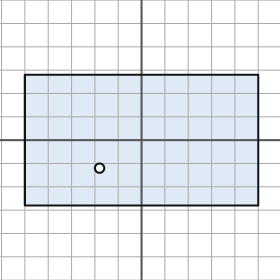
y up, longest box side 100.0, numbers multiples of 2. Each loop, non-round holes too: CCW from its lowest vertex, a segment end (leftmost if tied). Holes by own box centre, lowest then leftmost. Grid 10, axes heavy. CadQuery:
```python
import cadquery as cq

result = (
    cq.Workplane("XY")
    .moveTo(-50.0, -28.0)
    .lineTo(50.0, -28.0)
    .lineTo(50.0, 28.0)
    .lineTo(-50.0, 28.0)
    .close()
    .moveTo(-18.0, -12.0)
    .circle(2.0)
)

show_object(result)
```